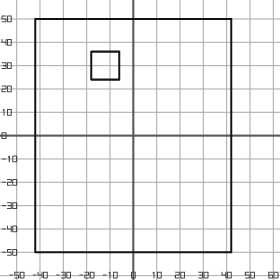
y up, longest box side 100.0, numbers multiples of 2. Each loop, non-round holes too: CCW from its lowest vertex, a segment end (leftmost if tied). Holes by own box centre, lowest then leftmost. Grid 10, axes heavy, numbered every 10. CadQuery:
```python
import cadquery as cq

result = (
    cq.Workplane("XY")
    .moveTo(-42.0, -50.0)
    .lineTo(42.0, -50.0)
    .lineTo(42.0, 50.0)
    .lineTo(-42.0, 50.0)
    .close()
    .moveTo(-18.0, 24.0)
    .lineTo(-6.0, 24.0)
    .lineTo(-6.0, 36.0)
    .lineTo(-18.0, 36.0)
    .close()
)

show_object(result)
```